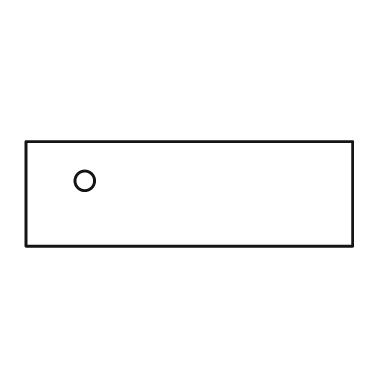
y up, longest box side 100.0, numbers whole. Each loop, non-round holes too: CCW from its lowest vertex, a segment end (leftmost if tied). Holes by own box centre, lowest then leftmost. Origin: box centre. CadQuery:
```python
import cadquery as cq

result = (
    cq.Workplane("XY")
    .moveTo(-50.0, -16.0)
    .lineTo(50.0, -16.0)
    .lineTo(50.0, 16.0)
    .lineTo(-50.0, 16.0)
    .close()
    .moveTo(-32.0, 4.0)
    .circle(3.0)
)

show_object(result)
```